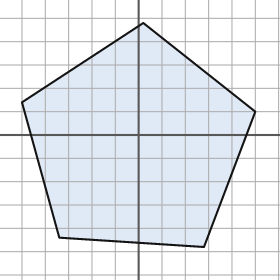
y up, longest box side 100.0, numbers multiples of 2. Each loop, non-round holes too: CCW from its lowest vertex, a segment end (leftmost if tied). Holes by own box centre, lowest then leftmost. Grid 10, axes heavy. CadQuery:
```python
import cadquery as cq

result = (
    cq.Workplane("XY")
    .moveTo(28.0, -48.0)
    .lineTo(50.0, 10.0)
    .lineTo(2.0, 48.0)
    .lineTo(-50.0, 14.0)
    .lineTo(-34.0, -44.0)
    .close()
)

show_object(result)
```